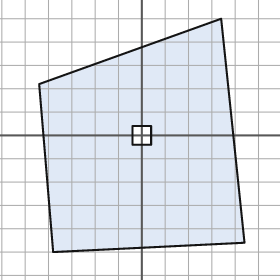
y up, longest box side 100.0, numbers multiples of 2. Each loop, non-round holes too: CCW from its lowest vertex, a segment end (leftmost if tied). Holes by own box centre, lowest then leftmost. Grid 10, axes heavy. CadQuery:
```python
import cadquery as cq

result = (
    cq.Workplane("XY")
    .moveTo(-38.0, -50.0)
    .lineTo(44.0, -46.0)
    .lineTo(34.0, 50.0)
    .lineTo(-44.0, 22.0)
    .close()
    .moveTo(-4.0, -4.0)
    .lineTo(4.0, -4.0)
    .lineTo(4.0, 4.0)
    .lineTo(-4.0, 4.0)
    .close()
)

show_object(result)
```